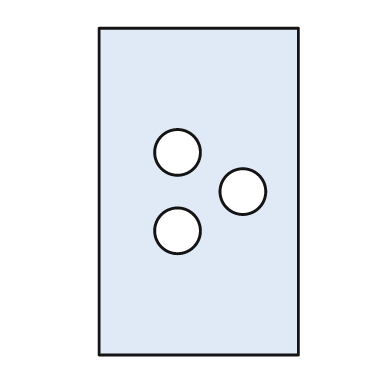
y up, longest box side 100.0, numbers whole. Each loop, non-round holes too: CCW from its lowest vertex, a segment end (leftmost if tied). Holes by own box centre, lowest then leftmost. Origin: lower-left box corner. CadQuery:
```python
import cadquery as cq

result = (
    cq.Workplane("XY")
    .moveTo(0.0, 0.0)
    .lineTo(61.0, 0.0)
    .lineTo(61.0, 100.0)
    .lineTo(0.0, 100.0)
    .close()
    .moveTo(24.0, 38.0)
    .circle(7.0)
    .moveTo(44.0, 50.0)
    .circle(7.0)
    .moveTo(24.0, 62.0)
    .circle(7.0)
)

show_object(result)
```